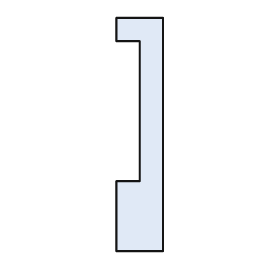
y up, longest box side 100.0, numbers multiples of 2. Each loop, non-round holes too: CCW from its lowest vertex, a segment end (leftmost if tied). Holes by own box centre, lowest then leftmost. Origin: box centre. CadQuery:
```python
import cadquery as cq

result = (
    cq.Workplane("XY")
    .moveTo(-10.0, -50.0)
    .lineTo(10.0, -50.0)
    .lineTo(10.0, 50.0)
    .lineTo(-10.0, 50.0)
    .lineTo(-10.0, 40.0)
    .lineTo(0.0, 40.0)
    .lineTo(0.0, -20.0)
    .lineTo(-10.0, -20.0)
    .close()
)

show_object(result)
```